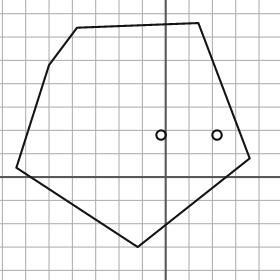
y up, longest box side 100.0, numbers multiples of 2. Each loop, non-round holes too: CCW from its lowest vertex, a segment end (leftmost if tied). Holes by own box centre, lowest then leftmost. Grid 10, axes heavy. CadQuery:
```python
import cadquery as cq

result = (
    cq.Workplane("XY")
    .moveTo(-12.0, -30.0)
    .lineTo(36.0, 8.0)
    .lineTo(14.0, 66.0)
    .lineTo(-38.0, 64.0)
    .lineTo(-50.0, 48.0)
    .lineTo(-64.0, 4.0)
    .close()
    .moveTo(-2.0, 18.0)
    .circle(2.0)
    .moveTo(22.0, 18.0)
    .circle(2.0)
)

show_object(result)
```